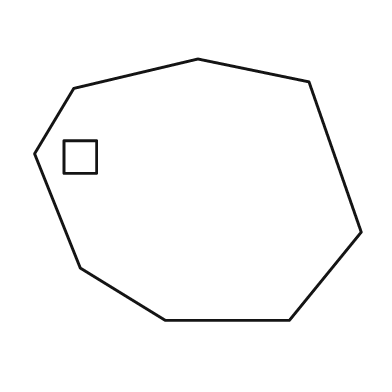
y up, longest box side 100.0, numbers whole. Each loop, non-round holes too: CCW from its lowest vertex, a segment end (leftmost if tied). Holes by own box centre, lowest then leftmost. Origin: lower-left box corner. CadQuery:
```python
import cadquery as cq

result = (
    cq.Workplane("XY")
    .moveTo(40.0, 0.0)
    .lineTo(78.0, 0.0)
    .lineTo(100.0, 27.0)
    .lineTo(84.0, 73.0)
    .lineTo(50.0, 80.0)
    .lineTo(12.0, 71.0)
    .lineTo(0.0, 51.0)
    .lineTo(14.0, 16.0)
    .close()
    .moveTo(9.0, 45.0)
    .lineTo(19.0, 45.0)
    .lineTo(19.0, 55.0)
    .lineTo(9.0, 55.0)
    .close()
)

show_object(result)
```